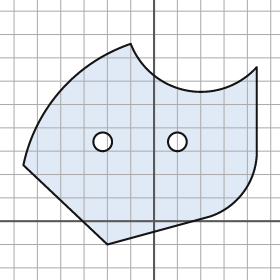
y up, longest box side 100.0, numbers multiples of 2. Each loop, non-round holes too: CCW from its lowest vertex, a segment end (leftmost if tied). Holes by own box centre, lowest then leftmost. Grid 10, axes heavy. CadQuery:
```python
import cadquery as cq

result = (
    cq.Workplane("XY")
    .moveTo(-20.0, -10.0)
    .lineTo(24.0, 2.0)
    .threePointArc((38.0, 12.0), (44.0, 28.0))
    .lineTo(44.0, 66.0)
    .threePointArc((14.0, 56.0), (-10.0, 76.0))
    .threePointArc((-40.0, 56.0), (-56.0, 24.0))
    .close()
    .moveTo(-22.0, 34.0)
    .circle(4.0)
    .moveTo(10.0, 34.0)
    .circle(4.0)
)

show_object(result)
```